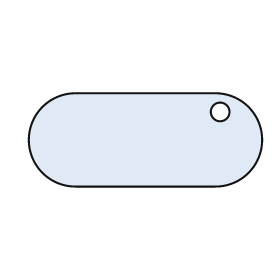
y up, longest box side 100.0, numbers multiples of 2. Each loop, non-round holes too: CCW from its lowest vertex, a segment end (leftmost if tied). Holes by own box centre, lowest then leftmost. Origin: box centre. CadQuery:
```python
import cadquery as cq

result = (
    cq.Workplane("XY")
    .moveTo(-30.0, -20.0)
    .lineTo(30.0, -20.0)
    .threePointArc((50.0, 0.0), (30.0, 20.0))
    .lineTo(-30.0, 20.0)
    .threePointArc((-50.0, 0.0), (-30.0, -20.0))
    .close()
    .moveTo(32.0, 12.0)
    .circle(4.0)
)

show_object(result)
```